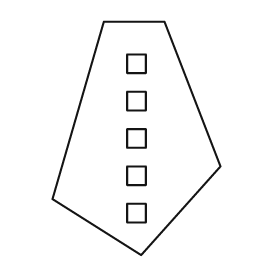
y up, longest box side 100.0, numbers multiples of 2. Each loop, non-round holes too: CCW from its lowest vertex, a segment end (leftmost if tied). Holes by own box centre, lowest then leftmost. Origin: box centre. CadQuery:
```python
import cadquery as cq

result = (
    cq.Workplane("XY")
    .moveTo(2.0, -50.0)
    .lineTo(36.0, -12.0)
    .lineTo(12.0, 50.0)
    .lineTo(-14.0, 50.0)
    .lineTo(-36.0, -26.0)
    .close()
    .moveTo(-4.0, -36.0)
    .lineTo(4.0, -36.0)
    .lineTo(4.0, -28.0)
    .lineTo(-4.0, -28.0)
    .close()
    .moveTo(-4.0, -20.0)
    .lineTo(4.0, -20.0)
    .lineTo(4.0, -12.0)
    .lineTo(-4.0, -12.0)
    .close()
    .moveTo(-4.0, -4.0)
    .lineTo(4.0, -4.0)
    .lineTo(4.0, 4.0)
    .lineTo(-4.0, 4.0)
    .close()
    .moveTo(-4.0, 12.0)
    .lineTo(4.0, 12.0)
    .lineTo(4.0, 20.0)
    .lineTo(-4.0, 20.0)
    .close()
    .moveTo(-4.0, 28.0)
    .lineTo(4.0, 28.0)
    .lineTo(4.0, 36.0)
    .lineTo(-4.0, 36.0)
    .close()
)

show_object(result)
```